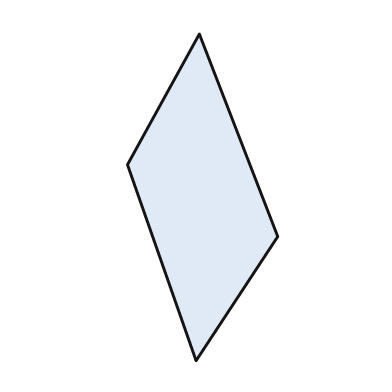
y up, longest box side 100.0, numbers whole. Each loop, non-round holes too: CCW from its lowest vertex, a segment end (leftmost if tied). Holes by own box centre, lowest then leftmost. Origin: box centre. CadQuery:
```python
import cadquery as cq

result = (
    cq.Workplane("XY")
    .moveTo(-2.0, -50.0)
    .lineTo(23.0, -12.0)
    .lineTo(-1.0, 50.0)
    .lineTo(-23.0, 10.0)
    .close()
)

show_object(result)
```